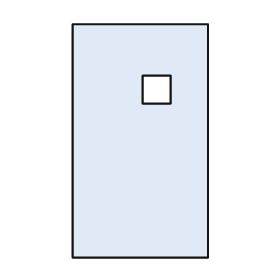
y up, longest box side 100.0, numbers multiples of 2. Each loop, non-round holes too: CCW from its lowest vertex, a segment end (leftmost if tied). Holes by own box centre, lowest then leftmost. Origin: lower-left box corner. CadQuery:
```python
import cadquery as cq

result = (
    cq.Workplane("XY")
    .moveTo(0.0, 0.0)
    .lineTo(58.0, 0.0)
    .lineTo(58.0, 100.0)
    .lineTo(0.0, 100.0)
    .close()
    .moveTo(30.0, 66.0)
    .lineTo(42.0, 66.0)
    .lineTo(42.0, 78.0)
    .lineTo(30.0, 78.0)
    .close()
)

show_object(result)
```